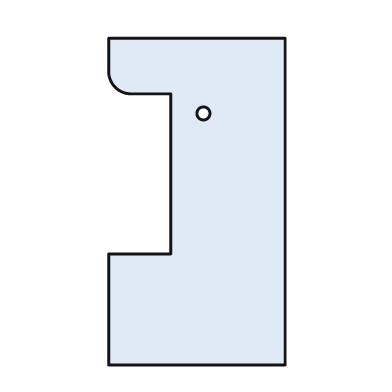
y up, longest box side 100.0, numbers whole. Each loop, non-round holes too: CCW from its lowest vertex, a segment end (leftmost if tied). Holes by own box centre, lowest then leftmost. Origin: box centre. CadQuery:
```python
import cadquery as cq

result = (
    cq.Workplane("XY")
    .moveTo(-27.0, -50.0)
    .lineTo(27.0, -50.0)
    .lineTo(27.0, 50.0)
    .lineTo(-27.0, 50.0)
    .lineTo(-27.0, 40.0)
    .threePointArc((-25.0, 35.0), (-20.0, 33.0))
    .lineTo(-8.0, 33.0)
    .lineTo(-8.0, -16.0)
    .lineTo(-27.0, -16.0)
    .close()
    .moveTo(2.0, 27.0)
    .circle(2.0)
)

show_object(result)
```